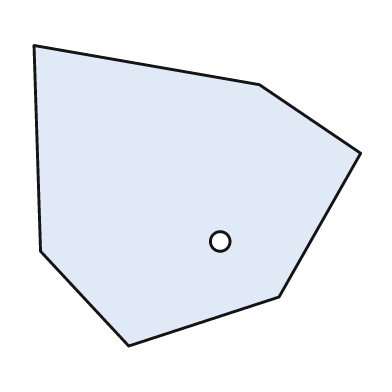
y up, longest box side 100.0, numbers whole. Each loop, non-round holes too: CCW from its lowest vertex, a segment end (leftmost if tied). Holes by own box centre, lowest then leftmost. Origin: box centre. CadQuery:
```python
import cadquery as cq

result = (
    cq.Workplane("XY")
    .moveTo(-21.0, -46.0)
    .lineTo(25.0, -31.0)
    .lineTo(50.0, 13.0)
    .lineTo(19.0, 34.0)
    .lineTo(-50.0, 46.0)
    .lineTo(-48.0, -17.0)
    .close()
    .moveTo(7.0, -14.0)
    .circle(3.0)
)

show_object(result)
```